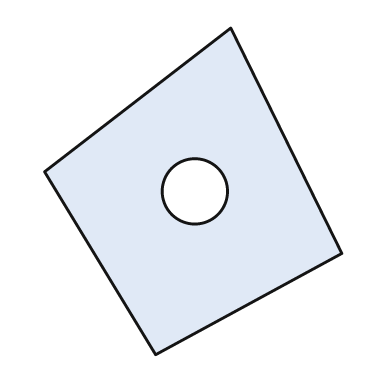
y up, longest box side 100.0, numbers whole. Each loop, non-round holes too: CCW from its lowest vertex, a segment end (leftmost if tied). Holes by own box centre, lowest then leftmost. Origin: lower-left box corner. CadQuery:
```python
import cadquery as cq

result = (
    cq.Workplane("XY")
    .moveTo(34.0, 0.0)
    .lineTo(91.0, 31.0)
    .lineTo(57.0, 100.0)
    .lineTo(0.0, 56.0)
    .close()
    .moveTo(46.0, 50.0)
    .circle(10.0)
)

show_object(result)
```